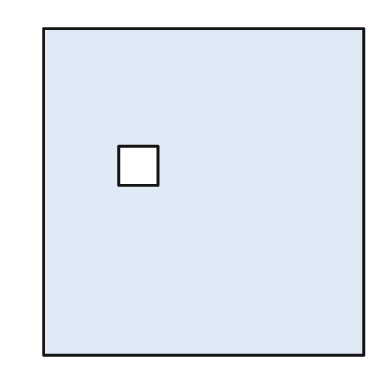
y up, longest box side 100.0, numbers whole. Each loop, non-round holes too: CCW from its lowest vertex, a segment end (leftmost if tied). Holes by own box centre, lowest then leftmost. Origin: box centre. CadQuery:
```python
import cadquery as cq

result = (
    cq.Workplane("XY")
    .moveTo(-49.0, -50.0)
    .lineTo(49.0, -50.0)
    .lineTo(49.0, 50.0)
    .lineTo(-49.0, 50.0)
    .close()
    .moveTo(-26.0, 2.0)
    .lineTo(-14.0, 2.0)
    .lineTo(-14.0, 14.0)
    .lineTo(-26.0, 14.0)
    .close()
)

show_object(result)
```